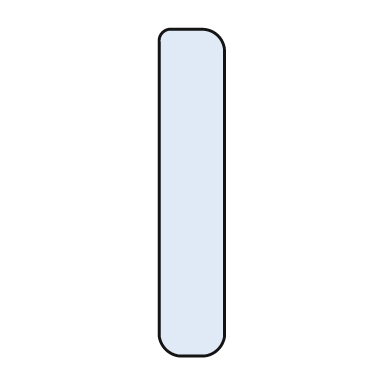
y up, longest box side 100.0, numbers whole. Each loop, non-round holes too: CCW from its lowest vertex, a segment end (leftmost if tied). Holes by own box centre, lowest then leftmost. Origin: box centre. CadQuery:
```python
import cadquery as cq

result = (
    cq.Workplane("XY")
    .moveTo(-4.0, -50.0)
    .lineTo(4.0, -50.0)
    .threePointArc((8.0, -48.0), (10.0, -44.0))
    .lineTo(10.0, 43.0)
    .threePointArc((8.0, 48.0), (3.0, 50.0))
    .lineTo(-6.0, 50.0)
    .threePointArc((-9.0, 49.0), (-10.0, 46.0))
    .lineTo(-10.0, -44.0)
    .threePointArc((-8.0, -48.0), (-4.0, -50.0))
    .close()
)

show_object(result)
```